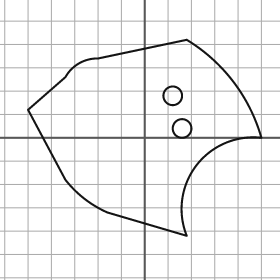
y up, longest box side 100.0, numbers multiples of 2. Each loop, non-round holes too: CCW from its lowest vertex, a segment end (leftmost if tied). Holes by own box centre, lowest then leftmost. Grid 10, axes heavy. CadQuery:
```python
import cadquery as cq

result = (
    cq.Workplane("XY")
    .moveTo(18.0, -42.0)
    .threePointArc((22.0, -12.0), (50.0, 0.0))
    .threePointArc((38.0, 24.0), (18.0, 42.0))
    .lineTo(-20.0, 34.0)
    .threePointArc((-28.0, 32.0), (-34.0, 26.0))
    .lineTo(-50.0, 12.0)
    .lineTo(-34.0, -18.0)
    .threePointArc((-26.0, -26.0), (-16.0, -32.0))
    .close()
    .moveTo(16.0, 4.0)
    .circle(4.0)
    .moveTo(12.0, 18.0)
    .circle(4.0)
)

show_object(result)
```